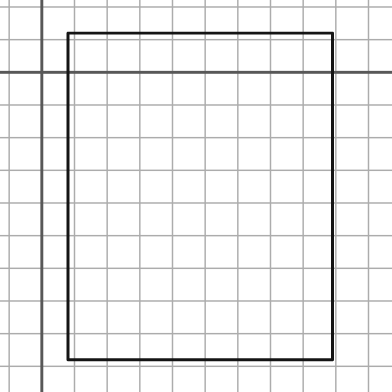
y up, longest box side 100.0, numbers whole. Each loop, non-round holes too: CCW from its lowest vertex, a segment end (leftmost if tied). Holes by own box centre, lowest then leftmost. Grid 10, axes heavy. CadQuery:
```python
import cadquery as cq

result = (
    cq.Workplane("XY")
    .moveTo(8.0, -88.0)
    .lineTo(89.0, -88.0)
    .lineTo(89.0, 12.0)
    .lineTo(8.0, 12.0)
    .close()
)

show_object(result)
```